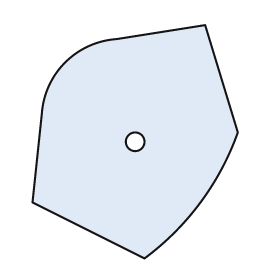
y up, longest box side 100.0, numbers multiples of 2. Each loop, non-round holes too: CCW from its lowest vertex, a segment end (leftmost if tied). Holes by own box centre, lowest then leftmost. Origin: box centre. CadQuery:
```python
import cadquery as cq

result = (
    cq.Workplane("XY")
    .moveTo(4.0, -50.0)
    .threePointArc((28.0, -26.0), (44.0, 4.0))
    .lineTo(30.0, 50.0)
    .lineTo(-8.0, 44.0)
    .threePointArc((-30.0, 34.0), (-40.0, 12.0))
    .lineTo(-44.0, -26.0)
    .close()
    .moveTo(0.0, 0.0)
    .circle(4.0)
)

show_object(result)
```